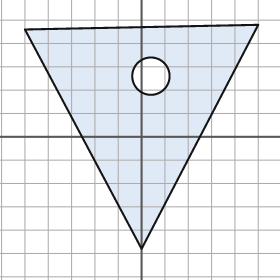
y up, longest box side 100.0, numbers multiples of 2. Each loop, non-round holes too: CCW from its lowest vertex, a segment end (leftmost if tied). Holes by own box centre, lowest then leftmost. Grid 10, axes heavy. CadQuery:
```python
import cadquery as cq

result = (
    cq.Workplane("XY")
    .moveTo(0.0, -48.0)
    .lineTo(50.0, 48.0)
    .lineTo(-50.0, 46.0)
    .close()
    .moveTo(4.0, 26.0)
    .circle(8.0)
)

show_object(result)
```